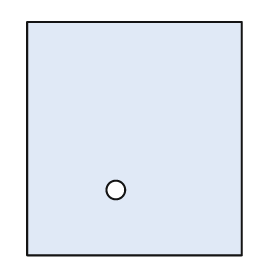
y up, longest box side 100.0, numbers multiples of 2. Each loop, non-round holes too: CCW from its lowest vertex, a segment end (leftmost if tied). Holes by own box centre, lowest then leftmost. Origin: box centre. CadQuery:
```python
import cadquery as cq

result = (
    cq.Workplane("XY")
    .moveTo(-46.0, -50.0)
    .lineTo(46.0, -50.0)
    .lineTo(46.0, 50.0)
    .lineTo(-46.0, 50.0)
    .close()
    .moveTo(-8.0, -22.0)
    .circle(4.0)
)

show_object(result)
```